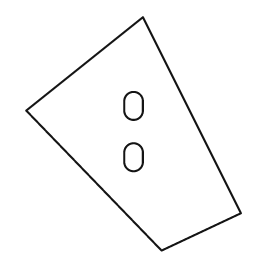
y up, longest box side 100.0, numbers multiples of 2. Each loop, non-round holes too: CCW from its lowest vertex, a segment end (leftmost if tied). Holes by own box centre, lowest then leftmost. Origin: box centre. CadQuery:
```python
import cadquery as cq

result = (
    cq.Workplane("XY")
    .moveTo(12.0, -50.0)
    .lineTo(46.0, -34.0)
    .lineTo(4.0, 50.0)
    .lineTo(-46.0, 10.0)
    .close()
    .moveTo(-4.0, -12.0)
    .threePointArc((0.0, -16.0), (4.0, -12.0))
    .lineTo(4.0, -8.0)
    .threePointArc((0.0, -4.0), (-4.0, -8.0))
    .close()
    .moveTo(-4.0, 10.0)
    .threePointArc((0.0, 6.0), (4.0, 10.0))
    .lineTo(4.0, 14.0)
    .threePointArc((0.0, 18.0), (-4.0, 14.0))
    .close()
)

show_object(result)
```